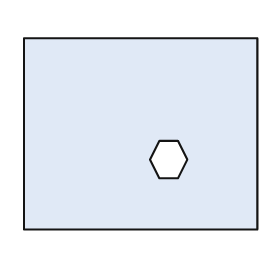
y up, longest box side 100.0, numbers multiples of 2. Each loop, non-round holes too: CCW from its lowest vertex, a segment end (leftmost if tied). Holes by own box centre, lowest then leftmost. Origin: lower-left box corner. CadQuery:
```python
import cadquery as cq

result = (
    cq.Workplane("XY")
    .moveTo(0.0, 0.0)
    .lineTo(100.0, 0.0)
    .lineTo(100.0, 82.0)
    .lineTo(0.0, 82.0)
    .close()
    .moveTo(58.0, 22.0)
    .lineTo(66.0, 22.0)
    .lineTo(70.0, 30.0)
    .lineTo(66.0, 38.0)
    .lineTo(58.0, 38.0)
    .lineTo(54.0, 30.0)
    .close()
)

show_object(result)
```